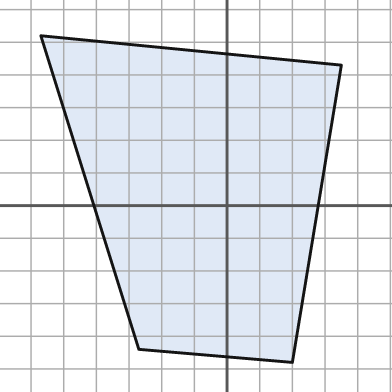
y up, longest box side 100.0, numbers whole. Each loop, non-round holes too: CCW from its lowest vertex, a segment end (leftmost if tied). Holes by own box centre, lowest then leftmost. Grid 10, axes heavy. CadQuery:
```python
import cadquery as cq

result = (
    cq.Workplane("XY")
    .moveTo(20.0, -48.0)
    .lineTo(35.0, 43.0)
    .lineTo(-57.0, 52.0)
    .lineTo(-27.0, -44.0)
    .close()
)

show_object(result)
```